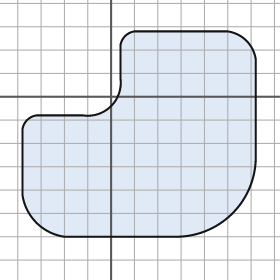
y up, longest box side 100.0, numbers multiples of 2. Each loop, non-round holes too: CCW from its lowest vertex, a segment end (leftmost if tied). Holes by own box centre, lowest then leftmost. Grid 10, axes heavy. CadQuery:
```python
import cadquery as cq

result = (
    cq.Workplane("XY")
    .moveTo(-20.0, -60.0)
    .lineTo(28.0, -60.0)
    .threePointArc((52.0, -50.0), (62.0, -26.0))
    .lineTo(62.0, 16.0)
    .threePointArc((58.0, 24.0), (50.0, 28.0))
    .lineTo(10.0, 28.0)
    .threePointArc((6.0, 26.0), (4.0, 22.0))
    .lineTo(4.0, 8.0)
    .threePointArc((0.0, -4.0), (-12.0, -8.0))
    .lineTo(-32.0, -8.0)
    .threePointArc((-36.0, -10.0), (-38.0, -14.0))
    .lineTo(-38.0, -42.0)
    .threePointArc((-32.0, -54.0), (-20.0, -60.0))
    .close()
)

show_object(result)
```